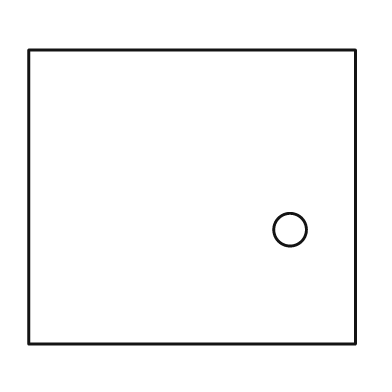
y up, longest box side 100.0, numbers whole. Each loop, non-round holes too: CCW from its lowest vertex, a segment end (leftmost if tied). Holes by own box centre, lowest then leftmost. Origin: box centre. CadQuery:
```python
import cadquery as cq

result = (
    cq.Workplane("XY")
    .moveTo(-50.0, -45.0)
    .lineTo(50.0, -45.0)
    .lineTo(50.0, 45.0)
    .lineTo(-50.0, 45.0)
    .close()
    .moveTo(30.0, -10.0)
    .circle(5.0)
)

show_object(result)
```